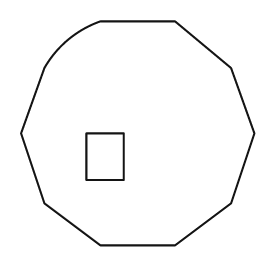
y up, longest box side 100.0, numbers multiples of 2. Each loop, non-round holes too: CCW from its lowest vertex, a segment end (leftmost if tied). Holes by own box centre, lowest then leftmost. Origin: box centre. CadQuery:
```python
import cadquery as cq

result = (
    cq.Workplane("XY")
    .moveTo(-16.0, -48.0)
    .lineTo(16.0, -48.0)
    .lineTo(40.0, -30.0)
    .lineTo(50.0, 0.0)
    .lineTo(40.0, 28.0)
    .lineTo(16.0, 48.0)
    .lineTo(-16.0, 48.0)
    .threePointArc((-30.0, 40.0), (-40.0, 28.0))
    .lineTo(-50.0, 0.0)
    .lineTo(-40.0, -30.0)
    .close()
    .moveTo(-22.0, -20.0)
    .lineTo(-6.0, -20.0)
    .lineTo(-6.0, 0.0)
    .lineTo(-22.0, 0.0)
    .close()
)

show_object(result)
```